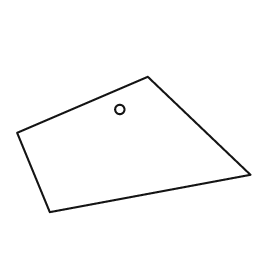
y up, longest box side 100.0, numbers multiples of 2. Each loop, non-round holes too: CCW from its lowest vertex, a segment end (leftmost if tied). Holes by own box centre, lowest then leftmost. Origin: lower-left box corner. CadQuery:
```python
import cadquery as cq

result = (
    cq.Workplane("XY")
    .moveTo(14.0, 0.0)
    .lineTo(100.0, 16.0)
    .lineTo(56.0, 58.0)
    .lineTo(0.0, 34.0)
    .close()
    .moveTo(44.0, 44.0)
    .circle(2.0)
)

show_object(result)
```